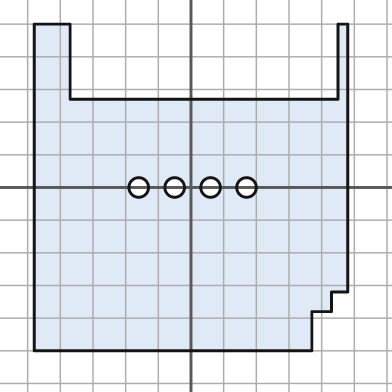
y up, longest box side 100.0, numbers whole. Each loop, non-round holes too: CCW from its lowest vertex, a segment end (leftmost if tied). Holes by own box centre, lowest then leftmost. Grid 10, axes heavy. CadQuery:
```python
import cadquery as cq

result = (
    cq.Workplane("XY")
    .moveTo(-48.0, -50.0)
    .lineTo(37.0, -50.0)
    .lineTo(37.0, -38.0)
    .lineTo(43.0, -38.0)
    .lineTo(43.0, -32.0)
    .lineTo(48.0, -32.0)
    .lineTo(48.0, 50.0)
    .lineTo(45.0, 50.0)
    .lineTo(45.0, 27.0)
    .lineTo(-37.0, 27.0)
    .lineTo(-37.0, 50.0)
    .lineTo(-48.0, 50.0)
    .close()
    .moveTo(-16.0, 0.0)
    .circle(3.0)
    .moveTo(-5.0, 0.0)
    .circle(3.0)
    .moveTo(6.0, 0.0)
    .circle(3.0)
    .moveTo(17.0, 0.0)
    .circle(3.0)
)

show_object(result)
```